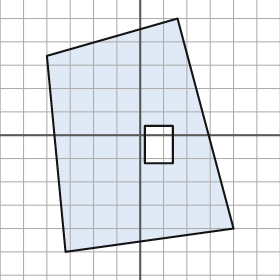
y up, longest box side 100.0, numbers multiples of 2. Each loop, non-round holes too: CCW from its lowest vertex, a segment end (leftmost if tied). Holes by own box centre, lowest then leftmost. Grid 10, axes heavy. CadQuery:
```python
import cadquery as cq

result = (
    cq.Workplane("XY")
    .moveTo(-32.0, -50.0)
    .lineTo(40.0, -40.0)
    .lineTo(16.0, 50.0)
    .lineTo(-40.0, 34.0)
    .close()
    .moveTo(2.0, -12.0)
    .lineTo(14.0, -12.0)
    .lineTo(14.0, 4.0)
    .lineTo(2.0, 4.0)
    .close()
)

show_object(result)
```